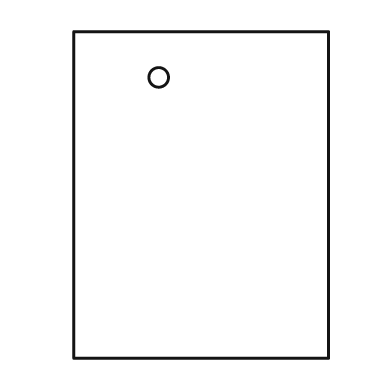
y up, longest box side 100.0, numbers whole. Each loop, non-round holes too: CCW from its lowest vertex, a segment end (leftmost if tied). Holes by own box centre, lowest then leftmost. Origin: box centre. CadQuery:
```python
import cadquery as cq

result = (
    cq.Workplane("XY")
    .moveTo(-39.0, -50.0)
    .lineTo(39.0, -50.0)
    .lineTo(39.0, 50.0)
    .lineTo(-39.0, 50.0)
    .close()
    .moveTo(-13.0, 36.0)
    .circle(3.0)
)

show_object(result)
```